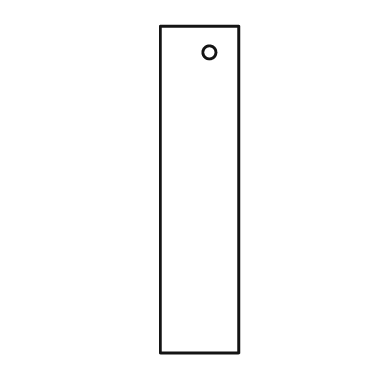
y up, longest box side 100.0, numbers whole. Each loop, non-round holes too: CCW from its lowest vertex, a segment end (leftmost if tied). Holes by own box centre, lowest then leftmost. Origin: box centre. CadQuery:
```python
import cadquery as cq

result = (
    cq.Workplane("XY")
    .moveTo(-12.0, -50.0)
    .lineTo(12.0, -50.0)
    .lineTo(12.0, 50.0)
    .lineTo(-12.0, 50.0)
    .close()
    .moveTo(3.0, 42.0)
    .circle(2.0)
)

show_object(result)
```